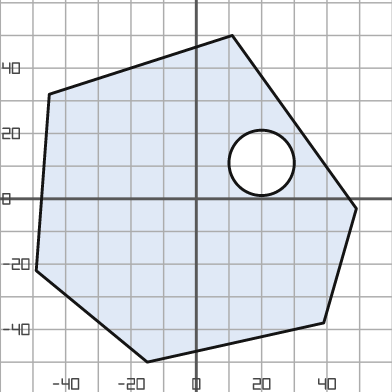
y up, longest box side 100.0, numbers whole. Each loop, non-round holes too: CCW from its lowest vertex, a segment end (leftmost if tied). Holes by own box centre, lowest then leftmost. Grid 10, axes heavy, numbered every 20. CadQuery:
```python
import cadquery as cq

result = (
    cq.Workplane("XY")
    .moveTo(-15.0, -50.0)
    .lineTo(39.0, -38.0)
    .lineTo(49.0, -3.0)
    .lineTo(11.0, 50.0)
    .lineTo(-45.0, 32.0)
    .lineTo(-49.0, -22.0)
    .close()
    .moveTo(20.0, 11.0)
    .circle(10.0)
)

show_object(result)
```